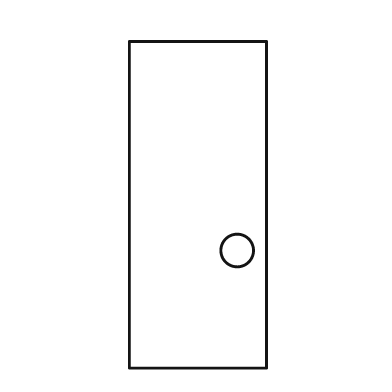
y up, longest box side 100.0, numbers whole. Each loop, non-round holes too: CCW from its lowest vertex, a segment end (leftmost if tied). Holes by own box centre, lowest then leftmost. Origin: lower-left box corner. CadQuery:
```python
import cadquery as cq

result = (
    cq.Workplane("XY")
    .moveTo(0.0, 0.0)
    .lineTo(42.0, 0.0)
    .lineTo(42.0, 100.0)
    .lineTo(0.0, 100.0)
    .close()
    .moveTo(33.0, 36.0)
    .circle(5.0)
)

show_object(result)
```